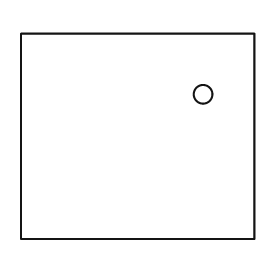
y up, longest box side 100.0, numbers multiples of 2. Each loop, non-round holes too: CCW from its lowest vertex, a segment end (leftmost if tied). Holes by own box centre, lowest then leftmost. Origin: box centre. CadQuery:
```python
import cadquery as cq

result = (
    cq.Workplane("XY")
    .moveTo(-50.0, -44.0)
    .lineTo(50.0, -44.0)
    .lineTo(50.0, 44.0)
    .lineTo(-50.0, 44.0)
    .close()
    .moveTo(28.0, 18.0)
    .circle(4.0)
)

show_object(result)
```